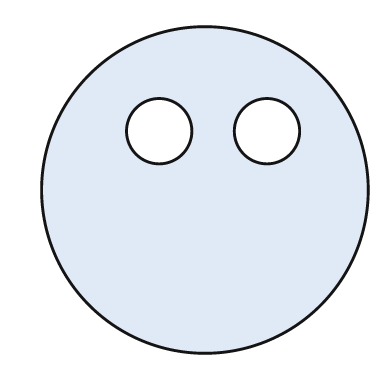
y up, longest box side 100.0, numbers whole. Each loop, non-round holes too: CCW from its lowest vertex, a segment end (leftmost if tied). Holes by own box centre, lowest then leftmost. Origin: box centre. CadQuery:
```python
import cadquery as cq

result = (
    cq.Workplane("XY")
    .moveTo(0.0, 0.0)
    .circle(50.0)
    .moveTo(-14.0, 18.0)
    .circle(10.0)
    .moveTo(19.0, 18.0)
    .circle(10.0)
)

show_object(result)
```